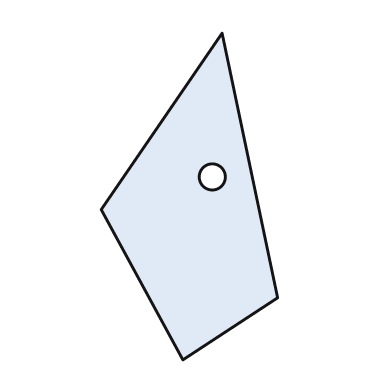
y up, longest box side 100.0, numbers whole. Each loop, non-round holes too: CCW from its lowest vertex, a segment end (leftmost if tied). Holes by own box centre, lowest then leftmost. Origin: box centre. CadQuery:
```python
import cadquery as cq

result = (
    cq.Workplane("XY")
    .moveTo(-2.0, -50.0)
    .lineTo(27.0, -31.0)
    .lineTo(10.0, 50.0)
    .lineTo(-27.0, -4.0)
    .close()
    .moveTo(7.0, 6.0)
    .circle(4.0)
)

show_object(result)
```